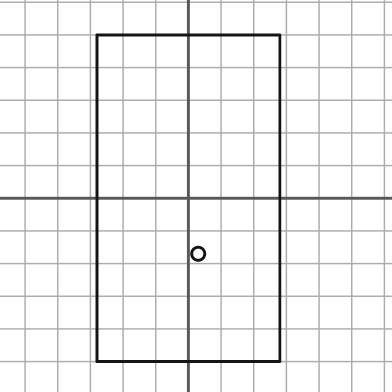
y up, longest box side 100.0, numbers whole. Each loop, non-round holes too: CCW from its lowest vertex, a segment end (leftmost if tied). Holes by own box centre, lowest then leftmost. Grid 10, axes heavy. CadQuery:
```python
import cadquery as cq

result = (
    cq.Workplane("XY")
    .moveTo(-28.0, -50.0)
    .lineTo(28.0, -50.0)
    .lineTo(28.0, 50.0)
    .lineTo(-28.0, 50.0)
    .close()
    .moveTo(3.0, -17.0)
    .circle(2.0)
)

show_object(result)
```